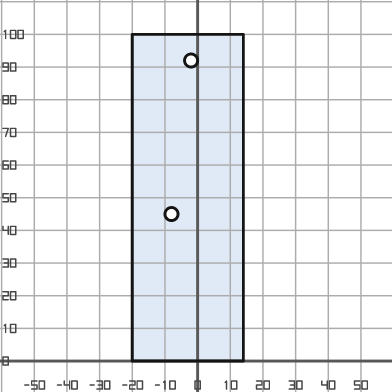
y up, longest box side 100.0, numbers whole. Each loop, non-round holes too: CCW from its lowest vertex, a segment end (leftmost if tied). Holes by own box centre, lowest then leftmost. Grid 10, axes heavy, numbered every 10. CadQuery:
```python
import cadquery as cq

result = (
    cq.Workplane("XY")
    .moveTo(-20.0, 0.0)
    .lineTo(14.0, 0.0)
    .lineTo(14.0, 100.0)
    .lineTo(-20.0, 100.0)
    .close()
    .moveTo(-8.0, 45.0)
    .circle(2.0)
    .moveTo(-2.0, 92.0)
    .circle(2.0)
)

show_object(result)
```